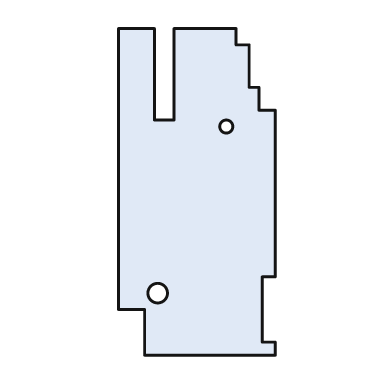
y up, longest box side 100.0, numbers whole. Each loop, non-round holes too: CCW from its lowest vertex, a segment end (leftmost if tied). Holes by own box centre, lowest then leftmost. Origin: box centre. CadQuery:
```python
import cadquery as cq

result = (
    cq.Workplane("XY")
    .moveTo(-16.0, -50.0)
    .lineTo(24.0, -50.0)
    .lineTo(24.0, -46.0)
    .lineTo(20.0, -46.0)
    .lineTo(20.0, -26.0)
    .lineTo(24.0, -26.0)
    .lineTo(24.0, 25.0)
    .lineTo(19.0, 25.0)
    .lineTo(19.0, 32.0)
    .lineTo(16.0, 32.0)
    .lineTo(16.0, 45.0)
    .lineTo(12.0, 45.0)
    .lineTo(12.0, 50.0)
    .lineTo(-7.0, 50.0)
    .lineTo(-7.0, 22.0)
    .lineTo(-13.0, 22.0)
    .lineTo(-13.0, 50.0)
    .lineTo(-24.0, 50.0)
    .lineTo(-24.0, -36.0)
    .lineTo(-16.0, -36.0)
    .close()
    .moveTo(-12.0, -31.0)
    .circle(3.0)
    .moveTo(9.0, 20.0)
    .circle(2.0)
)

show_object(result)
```